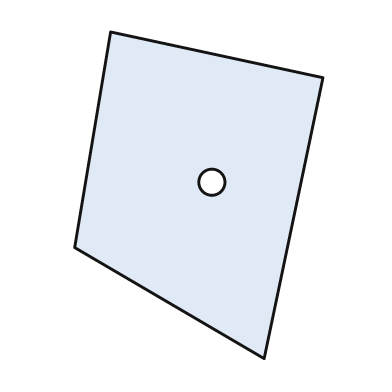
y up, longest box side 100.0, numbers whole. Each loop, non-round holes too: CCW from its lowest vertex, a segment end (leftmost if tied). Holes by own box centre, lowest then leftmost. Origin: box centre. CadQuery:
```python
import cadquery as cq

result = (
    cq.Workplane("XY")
    .moveTo(20.0, -50.0)
    .lineTo(38.0, 36.0)
    .lineTo(-27.0, 50.0)
    .lineTo(-38.0, -16.0)
    .close()
    .moveTo(4.0, 4.0)
    .circle(4.0)
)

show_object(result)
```